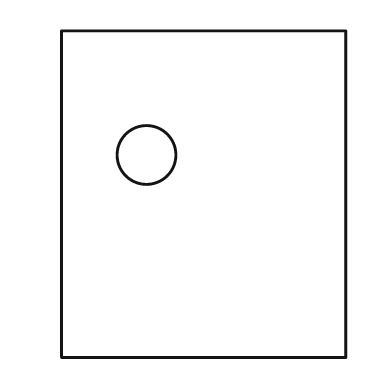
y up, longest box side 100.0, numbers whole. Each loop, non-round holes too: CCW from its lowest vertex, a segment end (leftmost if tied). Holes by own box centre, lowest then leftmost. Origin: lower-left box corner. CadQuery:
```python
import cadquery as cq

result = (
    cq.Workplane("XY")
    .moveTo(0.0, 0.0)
    .lineTo(87.0, 0.0)
    .lineTo(87.0, 100.0)
    .lineTo(0.0, 100.0)
    .close()
    .moveTo(26.0, 62.0)
    .circle(9.0)
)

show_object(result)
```